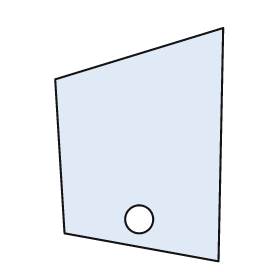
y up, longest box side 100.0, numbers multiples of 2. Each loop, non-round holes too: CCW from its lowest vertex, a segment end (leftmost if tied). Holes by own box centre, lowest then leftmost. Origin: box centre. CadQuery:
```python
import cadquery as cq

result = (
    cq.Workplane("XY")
    .moveTo(34.0, -50.0)
    .lineTo(36.0, 50.0)
    .lineTo(-36.0, 28.0)
    .lineTo(-32.0, -38.0)
    .close()
    .moveTo(0.0, -32.0)
    .circle(6.0)
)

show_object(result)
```